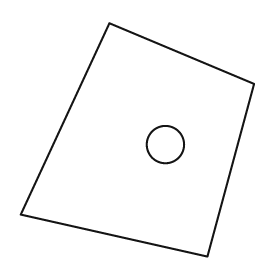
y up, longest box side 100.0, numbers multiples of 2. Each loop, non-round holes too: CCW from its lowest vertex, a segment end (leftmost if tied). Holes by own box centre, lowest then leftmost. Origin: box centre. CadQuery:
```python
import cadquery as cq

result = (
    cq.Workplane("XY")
    .moveTo(30.0, -50.0)
    .lineTo(50.0, 24.0)
    .lineTo(-12.0, 50.0)
    .lineTo(-50.0, -32.0)
    .close()
    .moveTo(12.0, -2.0)
    .circle(8.0)
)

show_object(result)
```